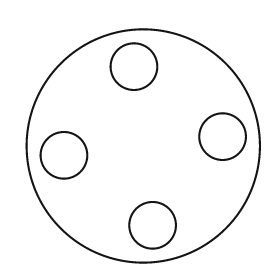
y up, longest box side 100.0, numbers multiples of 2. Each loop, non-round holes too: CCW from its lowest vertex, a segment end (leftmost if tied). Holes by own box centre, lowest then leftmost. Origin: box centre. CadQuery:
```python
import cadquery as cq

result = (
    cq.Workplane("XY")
    .moveTo(0.0, 0.0)
    .circle(50.0)
    .moveTo(4.0, -34.0)
    .circle(10.0)
    .moveTo(-34.0, -4.0)
    .circle(10.0)
    .moveTo(34.0, 4.0)
    .circle(10.0)
    .moveTo(-4.0, 34.0)
    .circle(10.0)
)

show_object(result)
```